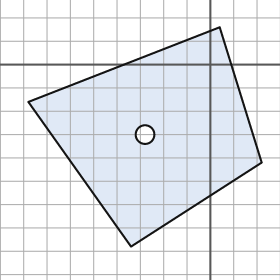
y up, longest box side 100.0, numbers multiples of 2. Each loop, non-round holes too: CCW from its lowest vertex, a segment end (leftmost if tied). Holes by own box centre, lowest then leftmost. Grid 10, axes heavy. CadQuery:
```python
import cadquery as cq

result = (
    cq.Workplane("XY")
    .moveTo(-34.0, -78.0)
    .lineTo(22.0, -42.0)
    .lineTo(4.0, 16.0)
    .lineTo(-78.0, -16.0)
    .close()
    .moveTo(-28.0, -30.0)
    .circle(4.0)
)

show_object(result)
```